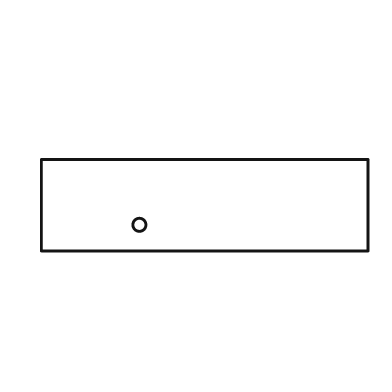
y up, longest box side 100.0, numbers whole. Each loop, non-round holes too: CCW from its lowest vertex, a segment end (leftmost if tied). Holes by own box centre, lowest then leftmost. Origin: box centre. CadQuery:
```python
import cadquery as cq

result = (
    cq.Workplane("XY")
    .moveTo(-50.0, -14.0)
    .lineTo(50.0, -14.0)
    .lineTo(50.0, 14.0)
    .lineTo(-50.0, 14.0)
    .close()
    .moveTo(-20.0, -6.0)
    .circle(2.0)
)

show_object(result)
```